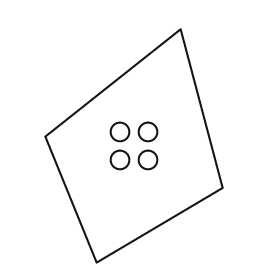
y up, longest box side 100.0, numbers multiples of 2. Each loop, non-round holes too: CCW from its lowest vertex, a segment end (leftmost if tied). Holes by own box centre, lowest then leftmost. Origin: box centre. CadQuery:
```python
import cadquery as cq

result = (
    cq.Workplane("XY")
    .moveTo(-16.0, -50.0)
    .lineTo(38.0, -18.0)
    .lineTo(20.0, 50.0)
    .lineTo(-38.0, 4.0)
    .close()
    .moveTo(-6.0, -6.0)
    .circle(4.0)
    .moveTo(6.0, -6.0)
    .circle(4.0)
    .moveTo(-6.0, 6.0)
    .circle(4.0)
    .moveTo(6.0, 6.0)
    .circle(4.0)
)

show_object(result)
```